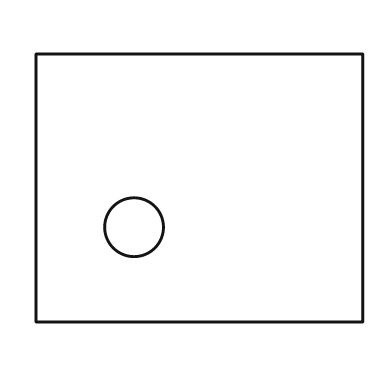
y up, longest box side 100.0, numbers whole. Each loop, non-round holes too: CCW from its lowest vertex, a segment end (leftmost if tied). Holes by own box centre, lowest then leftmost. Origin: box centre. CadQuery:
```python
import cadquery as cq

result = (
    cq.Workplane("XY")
    .moveTo(-50.0, -41.0)
    .lineTo(50.0, -41.0)
    .lineTo(50.0, 41.0)
    .lineTo(-50.0, 41.0)
    .close()
    .moveTo(-20.0, -12.0)
    .circle(9.0)
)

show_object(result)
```